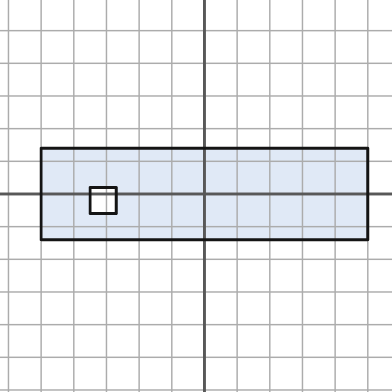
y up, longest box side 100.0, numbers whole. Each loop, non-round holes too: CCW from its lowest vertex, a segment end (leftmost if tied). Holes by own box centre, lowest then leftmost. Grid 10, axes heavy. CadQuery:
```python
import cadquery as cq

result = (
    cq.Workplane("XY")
    .moveTo(-50.0, -14.0)
    .lineTo(50.0, -14.0)
    .lineTo(50.0, 14.0)
    .lineTo(-50.0, 14.0)
    .close()
    .moveTo(-35.0, -6.0)
    .lineTo(-27.0, -6.0)
    .lineTo(-27.0, 2.0)
    .lineTo(-35.0, 2.0)
    .close()
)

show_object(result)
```